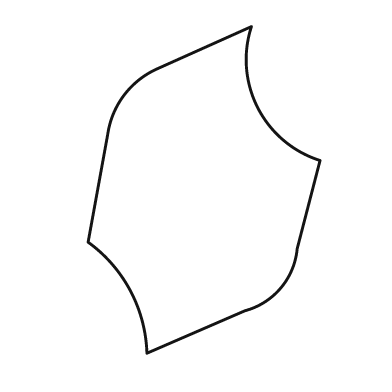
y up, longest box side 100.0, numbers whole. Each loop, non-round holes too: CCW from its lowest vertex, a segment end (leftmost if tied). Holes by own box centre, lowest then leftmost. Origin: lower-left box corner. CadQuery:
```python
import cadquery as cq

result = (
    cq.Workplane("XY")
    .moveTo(18.0, 0.0)
    .lineTo(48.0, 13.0)
    .threePointArc((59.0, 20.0), (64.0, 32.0))
    .lineTo(71.0, 59.0)
    .threePointArc((52.0, 75.0), (50.0, 100.0))
    .lineTo(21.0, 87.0)
    .threePointArc((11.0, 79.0), (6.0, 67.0))
    .lineTo(0.0, 34.0)
    .threePointArc((13.0, 19.0), (18.0, 0.0))
    .close()
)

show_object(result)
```